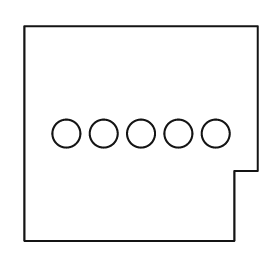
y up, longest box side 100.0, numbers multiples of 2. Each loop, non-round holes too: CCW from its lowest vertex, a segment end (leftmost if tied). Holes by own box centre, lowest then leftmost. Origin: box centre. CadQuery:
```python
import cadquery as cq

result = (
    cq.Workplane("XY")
    .moveTo(-50.0, -46.0)
    .lineTo(40.0, -46.0)
    .lineTo(40.0, -16.0)
    .lineTo(50.0, -16.0)
    .lineTo(50.0, 46.0)
    .lineTo(-50.0, 46.0)
    .close()
    .moveTo(-32.0, 0.0)
    .circle(6.0)
    .moveTo(-16.0, 0.0)
    .circle(6.0)
    .moveTo(0.0, 0.0)
    .circle(6.0)
    .moveTo(16.0, 0.0)
    .circle(6.0)
    .moveTo(32.0, 0.0)
    .circle(6.0)
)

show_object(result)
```